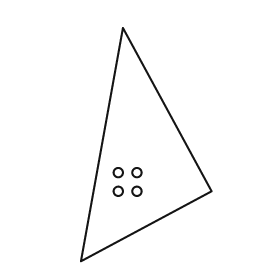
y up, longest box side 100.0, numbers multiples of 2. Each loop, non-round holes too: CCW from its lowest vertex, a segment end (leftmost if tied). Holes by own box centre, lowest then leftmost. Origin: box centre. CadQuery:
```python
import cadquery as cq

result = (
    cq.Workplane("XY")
    .moveTo(-28.0, -50.0)
    .lineTo(28.0, -20.0)
    .lineTo(-10.0, 50.0)
    .close()
    .moveTo(-12.0, -20.0)
    .circle(2.0)
    .moveTo(-4.0, -20.0)
    .circle(2.0)
    .moveTo(-12.0, -12.0)
    .circle(2.0)
    .moveTo(-4.0, -12.0)
    .circle(2.0)
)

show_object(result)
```